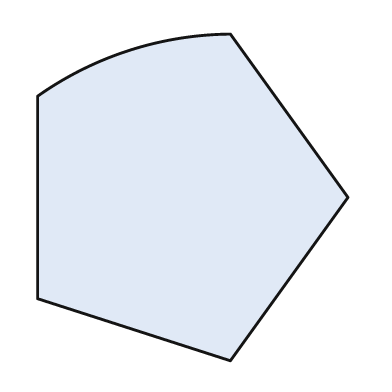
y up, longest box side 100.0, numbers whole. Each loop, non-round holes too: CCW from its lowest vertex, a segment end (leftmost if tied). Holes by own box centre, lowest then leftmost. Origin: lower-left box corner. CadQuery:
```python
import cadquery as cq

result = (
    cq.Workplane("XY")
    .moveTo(59.0, 0.0)
    .lineTo(95.0, 50.0)
    .lineTo(59.0, 100.0)
    .threePointArc((28.0, 95.0), (0.0, 81.0))
    .lineTo(0.0, 19.0)
    .close()
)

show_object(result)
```